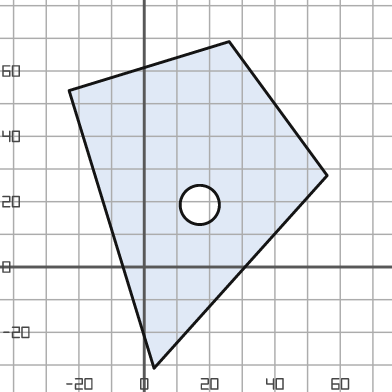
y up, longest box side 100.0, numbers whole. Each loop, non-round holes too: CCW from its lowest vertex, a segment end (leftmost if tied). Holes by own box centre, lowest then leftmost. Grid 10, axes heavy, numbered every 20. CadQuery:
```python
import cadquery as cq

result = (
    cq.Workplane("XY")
    .moveTo(3.0, -31.0)
    .lineTo(56.0, 28.0)
    .lineTo(26.0, 69.0)
    .lineTo(-23.0, 54.0)
    .close()
    .moveTo(17.0, 19.0)
    .circle(6.0)
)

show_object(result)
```